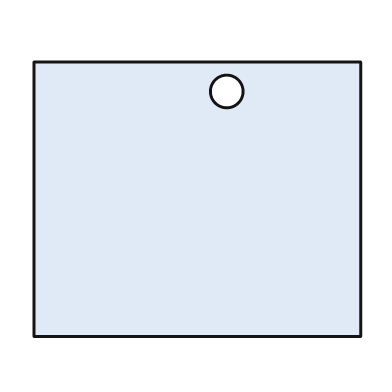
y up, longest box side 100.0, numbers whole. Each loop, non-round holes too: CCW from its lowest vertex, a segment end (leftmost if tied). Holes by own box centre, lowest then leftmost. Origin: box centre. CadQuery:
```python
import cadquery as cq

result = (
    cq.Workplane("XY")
    .moveTo(-50.0, -42.0)
    .lineTo(50.0, -42.0)
    .lineTo(50.0, 42.0)
    .lineTo(-50.0, 42.0)
    .close()
    .moveTo(9.0, 33.0)
    .circle(5.0)
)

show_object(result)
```